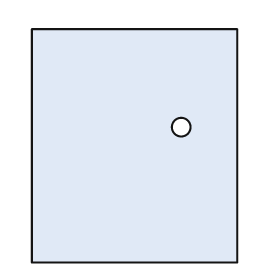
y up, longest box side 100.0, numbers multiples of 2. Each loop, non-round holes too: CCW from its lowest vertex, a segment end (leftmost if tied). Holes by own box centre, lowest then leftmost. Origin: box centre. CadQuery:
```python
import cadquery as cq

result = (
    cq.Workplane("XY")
    .moveTo(-44.0, -50.0)
    .lineTo(44.0, -50.0)
    .lineTo(44.0, 50.0)
    .lineTo(-44.0, 50.0)
    .close()
    .moveTo(20.0, 8.0)
    .circle(4.0)
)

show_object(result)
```